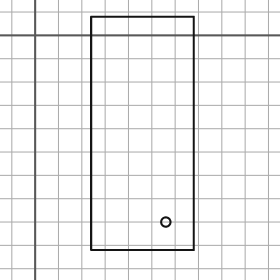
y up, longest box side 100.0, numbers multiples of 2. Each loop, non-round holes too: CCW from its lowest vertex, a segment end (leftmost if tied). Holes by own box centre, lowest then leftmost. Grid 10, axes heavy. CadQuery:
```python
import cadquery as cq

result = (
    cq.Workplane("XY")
    .moveTo(24.0, -92.0)
    .lineTo(68.0, -92.0)
    .lineTo(68.0, 8.0)
    .lineTo(24.0, 8.0)
    .close()
    .moveTo(56.0, -80.0)
    .circle(2.0)
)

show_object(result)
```